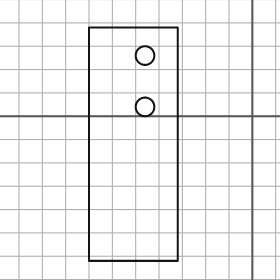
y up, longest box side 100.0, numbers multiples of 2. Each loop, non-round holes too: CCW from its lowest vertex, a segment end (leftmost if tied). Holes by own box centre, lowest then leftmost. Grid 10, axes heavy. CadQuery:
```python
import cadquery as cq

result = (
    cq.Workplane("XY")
    .moveTo(-70.0, -62.0)
    .lineTo(-32.0, -62.0)
    .lineTo(-32.0, 38.0)
    .lineTo(-70.0, 38.0)
    .close()
    .moveTo(-46.0, 4.0)
    .circle(4.0)
    .moveTo(-46.0, 26.0)
    .circle(4.0)
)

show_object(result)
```